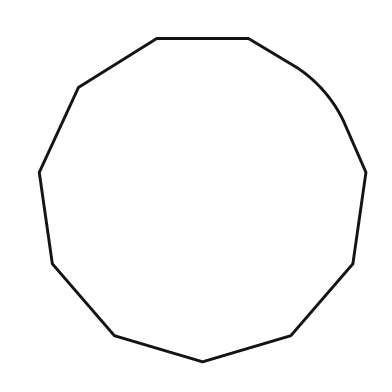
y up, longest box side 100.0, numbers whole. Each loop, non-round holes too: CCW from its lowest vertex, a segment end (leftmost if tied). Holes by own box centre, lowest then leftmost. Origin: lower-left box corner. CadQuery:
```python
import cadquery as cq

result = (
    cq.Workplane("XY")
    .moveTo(50.0, 0.0)
    .lineTo(77.0, 8.0)
    .lineTo(96.0, 30.0)
    .lineTo(100.0, 58.0)
    .lineTo(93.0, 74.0)
    .threePointArc((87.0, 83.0), (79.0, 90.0))
    .lineTo(64.0, 99.0)
    .lineTo(36.0, 99.0)
    .lineTo(12.0, 84.0)
    .lineTo(0.0, 58.0)
    .lineTo(4.0, 30.0)
    .lineTo(23.0, 8.0)
    .close()
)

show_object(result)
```